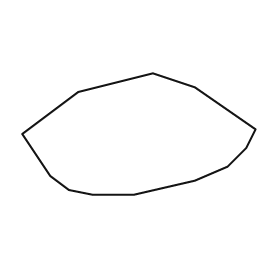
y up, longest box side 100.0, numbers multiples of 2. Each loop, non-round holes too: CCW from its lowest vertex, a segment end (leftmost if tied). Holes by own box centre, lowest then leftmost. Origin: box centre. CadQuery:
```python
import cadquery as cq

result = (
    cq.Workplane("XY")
    .moveTo(-20.0, -26.0)
    .lineTo(-2.0, -26.0)
    .lineTo(24.0, -20.0)
    .lineTo(38.0, -14.0)
    .lineTo(46.0, -6.0)
    .lineTo(50.0, 2.0)
    .lineTo(24.0, 20.0)
    .lineTo(6.0, 26.0)
    .lineTo(-26.0, 18.0)
    .lineTo(-50.0, 0.0)
    .lineTo(-38.0, -18.0)
    .lineTo(-30.0, -24.0)
    .close()
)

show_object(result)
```